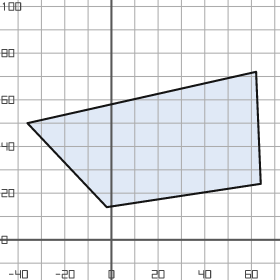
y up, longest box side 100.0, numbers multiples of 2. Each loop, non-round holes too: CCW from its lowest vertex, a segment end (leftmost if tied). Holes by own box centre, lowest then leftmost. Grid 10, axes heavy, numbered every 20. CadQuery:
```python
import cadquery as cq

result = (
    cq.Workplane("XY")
    .moveTo(-2.0, 14.0)
    .lineTo(64.0, 24.0)
    .lineTo(62.0, 72.0)
    .lineTo(-36.0, 50.0)
    .close()
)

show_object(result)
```